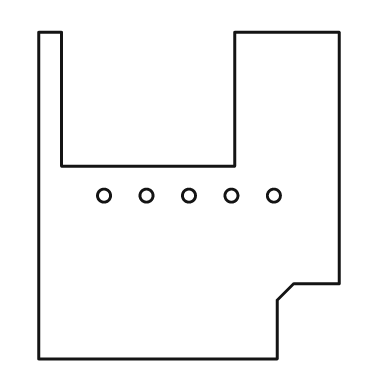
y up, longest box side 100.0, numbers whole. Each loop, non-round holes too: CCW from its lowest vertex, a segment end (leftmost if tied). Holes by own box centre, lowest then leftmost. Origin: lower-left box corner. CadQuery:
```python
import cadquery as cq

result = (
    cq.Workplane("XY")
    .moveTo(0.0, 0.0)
    .lineTo(73.0, 0.0)
    .lineTo(73.0, 18.0)
    .lineTo(78.0, 23.0)
    .lineTo(92.0, 23.0)
    .lineTo(92.0, 100.0)
    .lineTo(60.0, 100.0)
    .lineTo(60.0, 59.0)
    .lineTo(7.0, 59.0)
    .lineTo(7.0, 100.0)
    .lineTo(0.0, 100.0)
    .close()
    .moveTo(20.0, 50.0)
    .circle(2.0)
    .moveTo(33.0, 50.0)
    .circle(2.0)
    .moveTo(46.0, 50.0)
    .circle(2.0)
    .moveTo(59.0, 50.0)
    .circle(2.0)
    .moveTo(72.0, 50.0)
    .circle(2.0)
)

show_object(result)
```